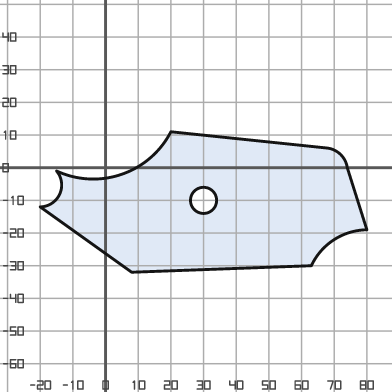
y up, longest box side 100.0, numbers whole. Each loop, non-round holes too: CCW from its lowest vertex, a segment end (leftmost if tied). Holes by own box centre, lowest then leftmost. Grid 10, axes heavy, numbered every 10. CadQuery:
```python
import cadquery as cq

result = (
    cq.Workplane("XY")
    .moveTo(8.0, -32.0)
    .lineTo(63.0, -30.0)
    .threePointArc((70.0, -22.0), (80.0, -19.0))
    .lineTo(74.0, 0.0)
    .threePointArc((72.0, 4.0), (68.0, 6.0))
    .lineTo(20.0, 11.0)
    .threePointArc((5.0, -2.0), (-15.0, -1.0))
    .threePointArc((-14.0, -8.0), (-20.0, -12.0))
    .close()
    .moveTo(30.0, -10.0)
    .circle(4.0)
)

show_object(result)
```